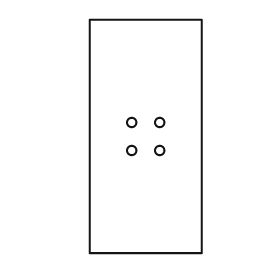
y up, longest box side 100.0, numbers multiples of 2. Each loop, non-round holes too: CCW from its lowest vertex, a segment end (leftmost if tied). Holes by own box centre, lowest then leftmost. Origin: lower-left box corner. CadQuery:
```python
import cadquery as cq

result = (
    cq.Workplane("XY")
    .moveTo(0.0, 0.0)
    .lineTo(48.0, 0.0)
    .lineTo(48.0, 100.0)
    .lineTo(0.0, 100.0)
    .close()
    .moveTo(18.0, 44.0)
    .circle(2.0)
    .moveTo(30.0, 44.0)
    .circle(2.0)
    .moveTo(18.0, 56.0)
    .circle(2.0)
    .moveTo(30.0, 56.0)
    .circle(2.0)
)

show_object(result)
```